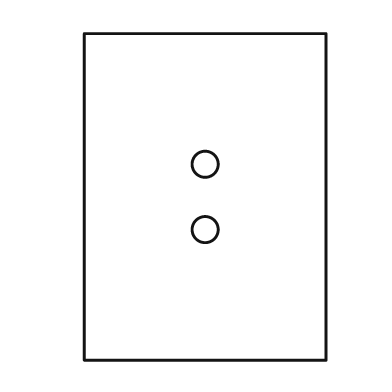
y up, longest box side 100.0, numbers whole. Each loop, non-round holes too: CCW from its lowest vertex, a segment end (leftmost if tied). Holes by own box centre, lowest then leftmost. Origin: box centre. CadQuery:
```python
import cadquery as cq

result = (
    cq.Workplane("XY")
    .moveTo(-37.0, -50.0)
    .lineTo(37.0, -50.0)
    .lineTo(37.0, 50.0)
    .lineTo(-37.0, 50.0)
    .close()
    .moveTo(0.0, -10.0)
    .circle(4.0)
    .moveTo(0.0, 10.0)
    .circle(4.0)
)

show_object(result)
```